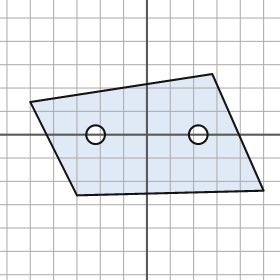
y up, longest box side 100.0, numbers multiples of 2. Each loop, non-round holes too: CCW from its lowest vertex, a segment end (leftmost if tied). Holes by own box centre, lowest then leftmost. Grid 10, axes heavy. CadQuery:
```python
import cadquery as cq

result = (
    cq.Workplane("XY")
    .moveTo(-30.0, -26.0)
    .lineTo(50.0, -24.0)
    .lineTo(28.0, 26.0)
    .lineTo(-50.0, 14.0)
    .close()
    .moveTo(-22.0, 0.0)
    .circle(4.0)
    .moveTo(22.0, 0.0)
    .circle(4.0)
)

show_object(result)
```